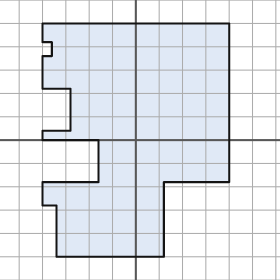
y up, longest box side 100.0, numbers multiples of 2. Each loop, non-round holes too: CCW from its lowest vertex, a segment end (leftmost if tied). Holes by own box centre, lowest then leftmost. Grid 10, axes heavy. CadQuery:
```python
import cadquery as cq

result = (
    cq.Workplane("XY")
    .moveTo(-34.0, -50.0)
    .lineTo(12.0, -50.0)
    .lineTo(12.0, -18.0)
    .lineTo(40.0, -18.0)
    .lineTo(40.0, 50.0)
    .lineTo(-40.0, 50.0)
    .lineTo(-40.0, 42.0)
    .lineTo(-36.0, 42.0)
    .lineTo(-36.0, 36.0)
    .lineTo(-40.0, 36.0)
    .lineTo(-40.0, 22.0)
    .lineTo(-28.0, 22.0)
    .lineTo(-28.0, 4.0)
    .lineTo(-40.0, 4.0)
    .lineTo(-40.0, 0.0)
    .lineTo(-16.0, 0.0)
    .lineTo(-16.0, -18.0)
    .lineTo(-40.0, -18.0)
    .lineTo(-40.0, -28.0)
    .lineTo(-34.0, -28.0)
    .close()
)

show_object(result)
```